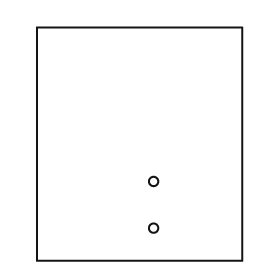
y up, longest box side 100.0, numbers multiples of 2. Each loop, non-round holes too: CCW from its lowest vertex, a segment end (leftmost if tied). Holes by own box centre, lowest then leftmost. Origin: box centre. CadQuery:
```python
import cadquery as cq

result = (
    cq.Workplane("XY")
    .moveTo(-44.0, -50.0)
    .lineTo(44.0, -50.0)
    .lineTo(44.0, 50.0)
    .lineTo(-44.0, 50.0)
    .close()
    .moveTo(6.0, -36.0)
    .circle(2.0)
    .moveTo(6.0, -16.0)
    .circle(2.0)
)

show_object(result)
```